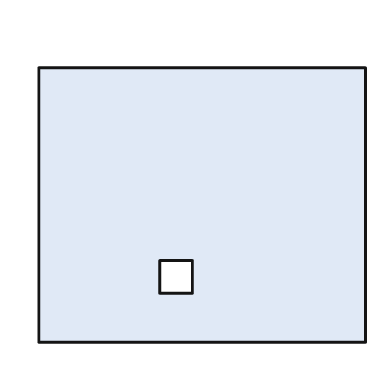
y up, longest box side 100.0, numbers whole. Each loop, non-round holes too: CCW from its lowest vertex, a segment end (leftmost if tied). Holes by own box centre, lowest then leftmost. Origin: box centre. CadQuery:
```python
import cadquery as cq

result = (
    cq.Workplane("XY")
    .moveTo(-50.0, -42.0)
    .lineTo(50.0, -42.0)
    .lineTo(50.0, 42.0)
    .lineTo(-50.0, 42.0)
    .close()
    .moveTo(-13.0, -27.0)
    .lineTo(-3.0, -27.0)
    .lineTo(-3.0, -17.0)
    .lineTo(-13.0, -17.0)
    .close()
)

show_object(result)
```